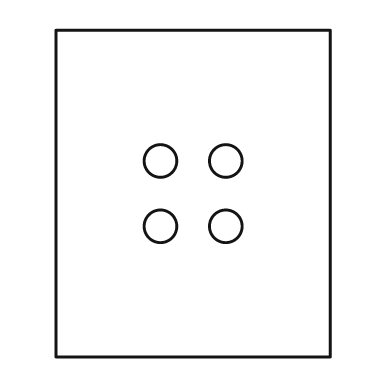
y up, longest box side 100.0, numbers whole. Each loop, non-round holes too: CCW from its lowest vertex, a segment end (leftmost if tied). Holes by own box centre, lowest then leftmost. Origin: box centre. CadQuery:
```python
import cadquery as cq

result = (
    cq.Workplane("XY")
    .moveTo(-42.0, -50.0)
    .lineTo(42.0, -50.0)
    .lineTo(42.0, 50.0)
    .lineTo(-42.0, 50.0)
    .close()
    .moveTo(-10.0, -10.0)
    .circle(5.0)
    .moveTo(10.0, -10.0)
    .circle(5.0)
    .moveTo(-10.0, 10.0)
    .circle(5.0)
    .moveTo(10.0, 10.0)
    .circle(5.0)
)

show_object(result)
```